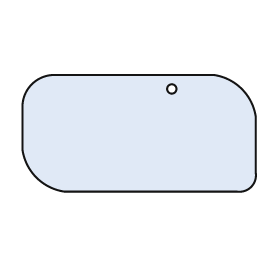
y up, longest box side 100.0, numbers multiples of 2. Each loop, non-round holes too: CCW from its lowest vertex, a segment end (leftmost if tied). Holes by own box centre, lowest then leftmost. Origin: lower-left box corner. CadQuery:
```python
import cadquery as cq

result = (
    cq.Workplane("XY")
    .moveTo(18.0, 0.0)
    .lineTo(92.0, 0.0)
    .threePointArc((98.0, 2.0), (100.0, 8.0))
    .lineTo(100.0, 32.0)
    .threePointArc((94.0, 44.0), (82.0, 50.0))
    .lineTo(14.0, 50.0)
    .threePointArc((4.0, 46.0), (0.0, 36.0))
    .lineTo(0.0, 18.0)
    .threePointArc((6.0, 6.0), (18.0, 0.0))
    .close()
    .moveTo(64.0, 44.0)
    .circle(2.0)
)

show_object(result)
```